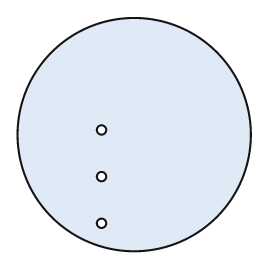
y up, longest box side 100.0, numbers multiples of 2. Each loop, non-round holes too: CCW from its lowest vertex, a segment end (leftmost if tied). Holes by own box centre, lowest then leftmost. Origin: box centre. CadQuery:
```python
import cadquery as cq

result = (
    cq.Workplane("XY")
    .moveTo(0.0, 0.0)
    .circle(50.0)
    .moveTo(-14.0, -38.0)
    .circle(2.0)
    .moveTo(-14.0, -18.0)
    .circle(2.0)
    .moveTo(-14.0, 2.0)
    .circle(2.0)
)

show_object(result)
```